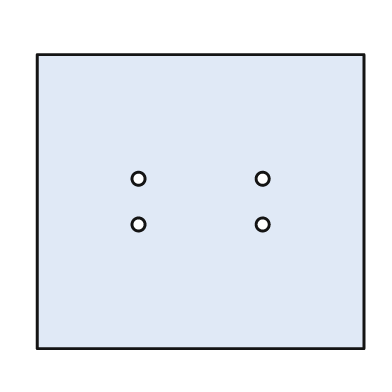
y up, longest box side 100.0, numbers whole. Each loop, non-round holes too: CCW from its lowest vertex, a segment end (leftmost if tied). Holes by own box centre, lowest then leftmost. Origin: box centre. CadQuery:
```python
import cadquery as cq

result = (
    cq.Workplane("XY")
    .moveTo(-50.0, -45.0)
    .lineTo(50.0, -45.0)
    .lineTo(50.0, 45.0)
    .lineTo(-50.0, 45.0)
    .close()
    .moveTo(-19.0, -7.0)
    .circle(2.0)
    .moveTo(19.0, -7.0)
    .circle(2.0)
    .moveTo(-19.0, 7.0)
    .circle(2.0)
    .moveTo(19.0, 7.0)
    .circle(2.0)
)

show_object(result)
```